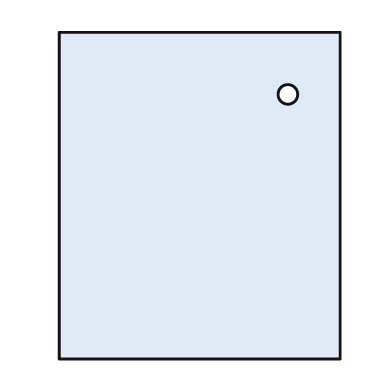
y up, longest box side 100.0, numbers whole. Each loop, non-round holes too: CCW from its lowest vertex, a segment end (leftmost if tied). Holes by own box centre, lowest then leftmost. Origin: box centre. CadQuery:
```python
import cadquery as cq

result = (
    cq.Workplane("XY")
    .moveTo(-43.0, -50.0)
    .lineTo(43.0, -50.0)
    .lineTo(43.0, 50.0)
    .lineTo(-43.0, 50.0)
    .close()
    .moveTo(27.0, 31.0)
    .circle(3.0)
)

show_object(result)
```